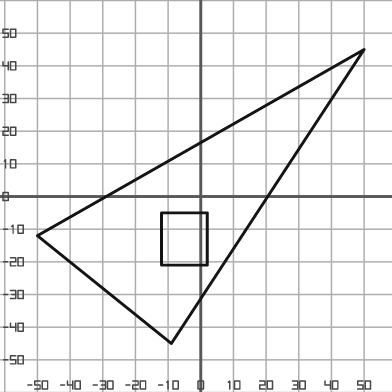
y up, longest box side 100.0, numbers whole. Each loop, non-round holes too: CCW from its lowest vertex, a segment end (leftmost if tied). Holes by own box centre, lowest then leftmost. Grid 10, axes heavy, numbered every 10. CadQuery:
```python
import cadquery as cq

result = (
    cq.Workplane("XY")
    .moveTo(-9.0, -45.0)
    .lineTo(50.0, 45.0)
    .lineTo(-50.0, -12.0)
    .close()
    .moveTo(-12.0, -21.0)
    .lineTo(2.0, -21.0)
    .lineTo(2.0, -5.0)
    .lineTo(-12.0, -5.0)
    .close()
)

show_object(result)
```